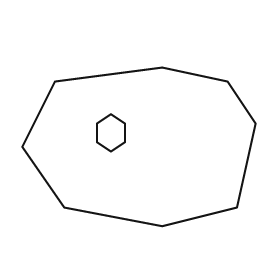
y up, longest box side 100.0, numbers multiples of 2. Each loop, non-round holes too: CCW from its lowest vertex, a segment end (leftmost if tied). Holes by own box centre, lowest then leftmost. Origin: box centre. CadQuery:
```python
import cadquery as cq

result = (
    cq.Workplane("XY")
    .moveTo(10.0, -34.0)
    .lineTo(42.0, -26.0)
    .lineTo(50.0, 10.0)
    .lineTo(38.0, 28.0)
    .lineTo(10.0, 34.0)
    .lineTo(-36.0, 28.0)
    .lineTo(-50.0, 0.0)
    .lineTo(-32.0, -26.0)
    .close()
    .moveTo(-12.0, -2.0)
    .lineTo(-6.0, 2.0)
    .lineTo(-6.0, 10.0)
    .lineTo(-12.0, 14.0)
    .lineTo(-18.0, 10.0)
    .lineTo(-18.0, 2.0)
    .close()
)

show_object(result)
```